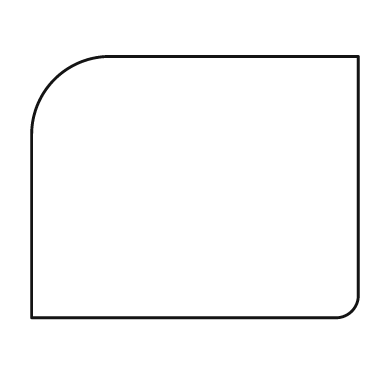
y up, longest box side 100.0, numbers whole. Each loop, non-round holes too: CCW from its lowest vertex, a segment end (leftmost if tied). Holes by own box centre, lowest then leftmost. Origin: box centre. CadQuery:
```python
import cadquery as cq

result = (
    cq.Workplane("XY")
    .moveTo(-50.0, -40.0)
    .lineTo(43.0, -40.0)
    .threePointArc((48.0, -38.0), (50.0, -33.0))
    .lineTo(50.0, 40.0)
    .lineTo(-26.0, 40.0)
    .threePointArc((-43.0, 33.0), (-50.0, 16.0))
    .close()
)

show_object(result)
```